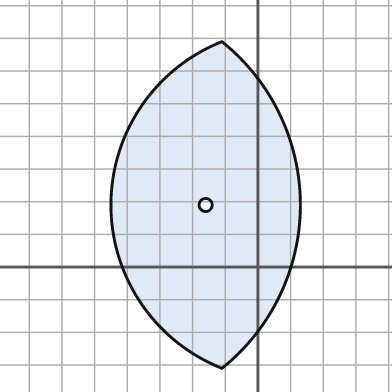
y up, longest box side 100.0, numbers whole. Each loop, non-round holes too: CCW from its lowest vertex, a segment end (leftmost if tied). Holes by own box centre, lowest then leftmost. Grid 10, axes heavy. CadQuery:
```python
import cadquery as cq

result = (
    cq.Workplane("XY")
    .moveTo(-11.0, -31.0)
    .threePointArc((13.0, 19.0), (-11.0, 69.0))
    .threePointArc((-45.0, 19.0), (-11.0, -31.0))
    .close()
    .moveTo(-16.0, 19.0)
    .circle(2.0)
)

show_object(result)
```